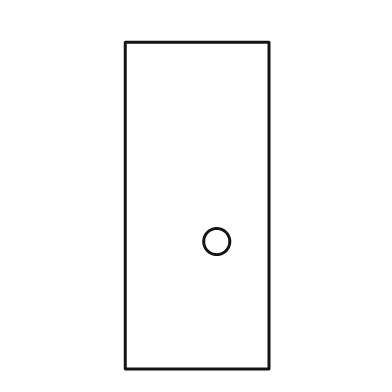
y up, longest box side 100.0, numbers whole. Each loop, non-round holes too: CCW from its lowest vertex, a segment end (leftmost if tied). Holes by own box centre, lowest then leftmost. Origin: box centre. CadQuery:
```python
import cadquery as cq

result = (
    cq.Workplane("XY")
    .moveTo(-22.0, -50.0)
    .lineTo(22.0, -50.0)
    .lineTo(22.0, 50.0)
    .lineTo(-22.0, 50.0)
    .close()
    .moveTo(6.0, -11.0)
    .circle(4.0)
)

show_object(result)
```